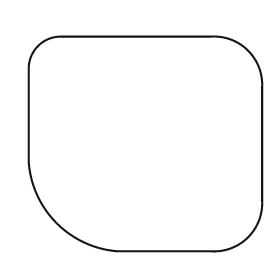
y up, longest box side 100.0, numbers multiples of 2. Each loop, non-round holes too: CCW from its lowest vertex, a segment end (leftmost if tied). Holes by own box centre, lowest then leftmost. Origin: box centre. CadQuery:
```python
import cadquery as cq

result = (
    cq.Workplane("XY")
    .moveTo(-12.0, -46.0)
    .lineTo(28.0, -46.0)
    .threePointArc((44.0, -40.0), (50.0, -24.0))
    .lineTo(50.0, 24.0)
    .threePointArc((44.0, 40.0), (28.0, 46.0))
    .lineTo(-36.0, 46.0)
    .threePointArc((-46.0, 42.0), (-50.0, 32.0))
    .lineTo(-50.0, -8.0)
    .threePointArc((-38.0, -34.0), (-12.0, -46.0))
    .close()
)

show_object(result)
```